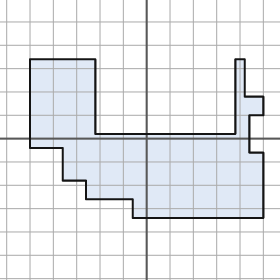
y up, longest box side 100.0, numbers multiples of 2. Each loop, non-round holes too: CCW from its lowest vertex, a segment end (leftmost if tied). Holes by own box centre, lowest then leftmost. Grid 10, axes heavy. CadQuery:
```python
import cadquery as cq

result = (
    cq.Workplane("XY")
    .moveTo(-6.0, -34.0)
    .lineTo(50.0, -34.0)
    .lineTo(50.0, -6.0)
    .lineTo(44.0, -6.0)
    .lineTo(44.0, 10.0)
    .lineTo(50.0, 10.0)
    .lineTo(50.0, 18.0)
    .lineTo(42.0, 18.0)
    .lineTo(42.0, 34.0)
    .lineTo(38.0, 34.0)
    .lineTo(38.0, 2.0)
    .lineTo(-22.0, 2.0)
    .lineTo(-22.0, 34.0)
    .lineTo(-50.0, 34.0)
    .lineTo(-50.0, -4.0)
    .lineTo(-36.0, -4.0)
    .lineTo(-36.0, -18.0)
    .lineTo(-26.0, -18.0)
    .lineTo(-26.0, -26.0)
    .lineTo(-6.0, -26.0)
    .close()
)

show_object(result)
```